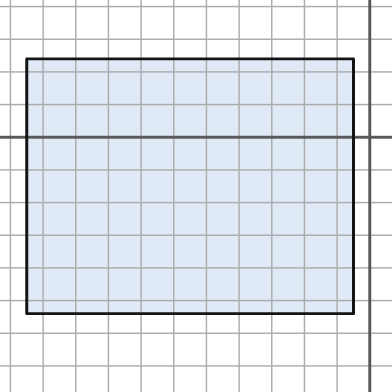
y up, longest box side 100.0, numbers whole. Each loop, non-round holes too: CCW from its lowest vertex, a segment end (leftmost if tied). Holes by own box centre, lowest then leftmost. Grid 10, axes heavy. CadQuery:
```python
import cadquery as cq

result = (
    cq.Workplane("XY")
    .moveTo(-105.0, -54.0)
    .lineTo(-5.0, -54.0)
    .lineTo(-5.0, 24.0)
    .lineTo(-105.0, 24.0)
    .close()
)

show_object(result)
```